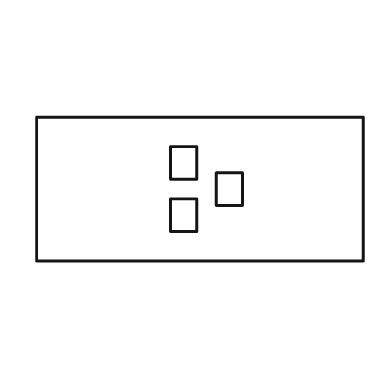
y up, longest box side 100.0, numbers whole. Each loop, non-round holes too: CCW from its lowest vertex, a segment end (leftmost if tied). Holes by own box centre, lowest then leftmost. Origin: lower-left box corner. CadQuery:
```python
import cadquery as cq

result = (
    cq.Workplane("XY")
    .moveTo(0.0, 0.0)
    .lineTo(100.0, 0.0)
    .lineTo(100.0, 44.0)
    .lineTo(0.0, 44.0)
    .close()
    .moveTo(41.0, 9.0)
    .lineTo(49.0, 9.0)
    .lineTo(49.0, 19.0)
    .lineTo(41.0, 19.0)
    .close()
    .moveTo(55.0, 17.0)
    .lineTo(63.0, 17.0)
    .lineTo(63.0, 27.0)
    .lineTo(55.0, 27.0)
    .close()
    .moveTo(41.0, 25.0)
    .lineTo(49.0, 25.0)
    .lineTo(49.0, 35.0)
    .lineTo(41.0, 35.0)
    .close()
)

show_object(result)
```